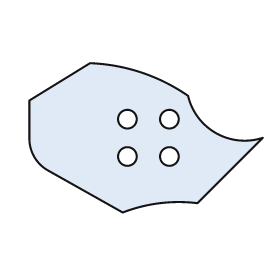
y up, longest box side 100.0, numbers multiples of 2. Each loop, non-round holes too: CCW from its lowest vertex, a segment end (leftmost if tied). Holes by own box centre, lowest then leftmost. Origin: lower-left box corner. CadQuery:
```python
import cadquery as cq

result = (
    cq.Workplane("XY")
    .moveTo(40.0, 0.0)
    .threePointArc((56.0, 4.0), (72.0, 4.0))
    .lineTo(100.0, 32.0)
    .threePointArc((80.0, 34.0), (68.0, 50.0))
    .threePointArc((48.0, 60.0), (26.0, 64.0))
    .lineTo(0.0, 48.0)
    .lineTo(0.0, 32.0)
    .threePointArc((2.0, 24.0), (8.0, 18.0))
    .close()
    .moveTo(42.0, 24.0)
    .circle(4.0)
    .moveTo(60.0, 24.0)
    .circle(4.0)
    .moveTo(42.0, 40.0)
    .circle(4.0)
    .moveTo(60.0, 40.0)
    .circle(4.0)
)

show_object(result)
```